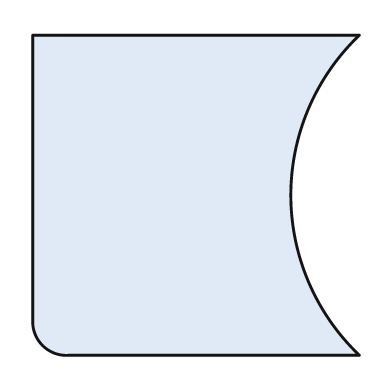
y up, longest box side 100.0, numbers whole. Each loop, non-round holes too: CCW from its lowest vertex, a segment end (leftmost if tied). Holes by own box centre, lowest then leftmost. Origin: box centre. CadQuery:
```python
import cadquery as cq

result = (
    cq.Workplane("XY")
    .moveTo(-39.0, -49.0)
    .lineTo(50.0, -49.0)
    .threePointArc((29.0, 0.0), (50.0, 49.0))
    .lineTo(-50.0, 49.0)
    .lineTo(-50.0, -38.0)
    .threePointArc((-47.0, -46.0), (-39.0, -49.0))
    .close()
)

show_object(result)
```